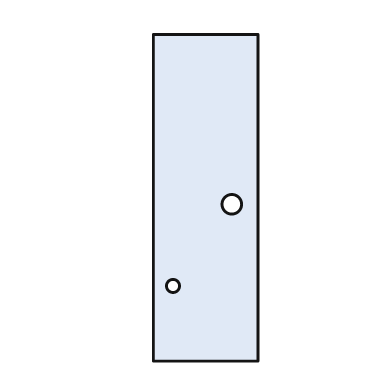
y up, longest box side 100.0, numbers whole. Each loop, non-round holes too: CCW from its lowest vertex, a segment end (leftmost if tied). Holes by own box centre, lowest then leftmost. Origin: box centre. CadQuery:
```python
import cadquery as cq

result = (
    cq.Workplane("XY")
    .moveTo(-16.0, -50.0)
    .lineTo(16.0, -50.0)
    .lineTo(16.0, 50.0)
    .lineTo(-16.0, 50.0)
    .close()
    .moveTo(-10.0, -27.0)
    .circle(2.0)
    .moveTo(8.0, -2.0)
    .circle(3.0)
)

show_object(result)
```